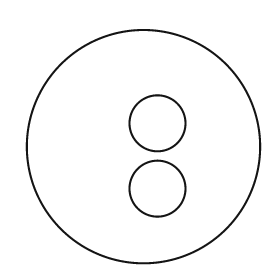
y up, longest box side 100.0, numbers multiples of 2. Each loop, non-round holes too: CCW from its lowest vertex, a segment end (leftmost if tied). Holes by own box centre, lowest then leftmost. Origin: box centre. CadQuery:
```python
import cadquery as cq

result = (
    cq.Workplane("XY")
    .moveTo(0.0, 0.0)
    .circle(50.0)
    .moveTo(6.0, -18.0)
    .circle(12.0)
    .moveTo(6.0, 10.0)
    .circle(12.0)
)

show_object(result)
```